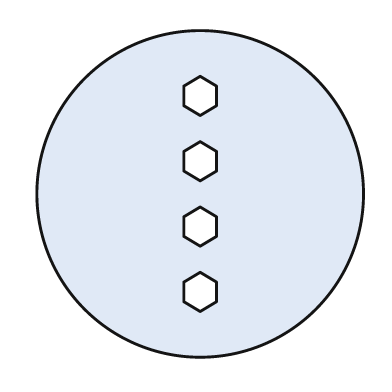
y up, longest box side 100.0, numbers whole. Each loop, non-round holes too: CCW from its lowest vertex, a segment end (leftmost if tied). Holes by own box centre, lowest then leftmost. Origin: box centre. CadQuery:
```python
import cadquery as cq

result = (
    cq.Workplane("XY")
    .moveTo(0.0, 0.0)
    .circle(50.0)
    .moveTo(0.0, -36.0)
    .lineTo(5.0, -33.0)
    .lineTo(5.0, -27.0)
    .lineTo(0.0, -24.0)
    .lineTo(-5.0, -27.0)
    .lineTo(-5.0, -33.0)
    .close()
    .moveTo(0.0, -16.0)
    .lineTo(5.0, -13.0)
    .lineTo(5.0, -7.0)
    .lineTo(0.0, -4.0)
    .lineTo(-5.0, -7.0)
    .lineTo(-5.0, -13.0)
    .close()
    .moveTo(0.0, 4.0)
    .lineTo(5.0, 7.0)
    .lineTo(5.0, 13.0)
    .lineTo(0.0, 16.0)
    .lineTo(-5.0, 13.0)
    .lineTo(-5.0, 7.0)
    .close()
    .moveTo(0.0, 24.0)
    .lineTo(5.0, 27.0)
    .lineTo(5.0, 33.0)
    .lineTo(0.0, 36.0)
    .lineTo(-5.0, 33.0)
    .lineTo(-5.0, 27.0)
    .close()
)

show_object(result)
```